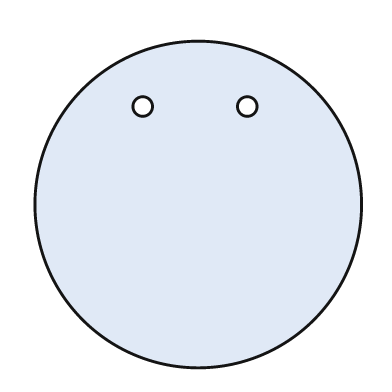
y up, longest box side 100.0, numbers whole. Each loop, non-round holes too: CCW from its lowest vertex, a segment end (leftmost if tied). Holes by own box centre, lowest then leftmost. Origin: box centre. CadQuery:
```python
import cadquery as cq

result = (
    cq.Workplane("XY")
    .moveTo(0.0, 0.0)
    .circle(50.0)
    .moveTo(-17.0, 30.0)
    .circle(3.0)
    .moveTo(15.0, 30.0)
    .circle(3.0)
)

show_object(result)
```